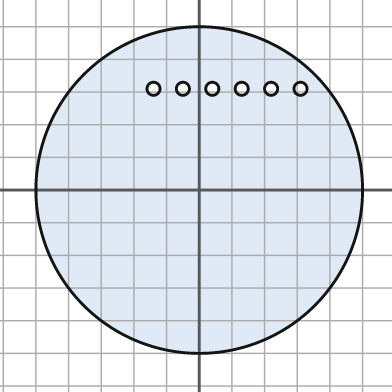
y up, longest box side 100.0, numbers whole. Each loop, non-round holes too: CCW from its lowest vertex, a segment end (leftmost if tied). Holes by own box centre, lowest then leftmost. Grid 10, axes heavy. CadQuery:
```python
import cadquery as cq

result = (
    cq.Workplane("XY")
    .moveTo(0.0, 0.0)
    .circle(50.0)
    .moveTo(-14.0, 31.0)
    .circle(2.0)
    .moveTo(-5.0, 31.0)
    .circle(2.0)
    .moveTo(4.0, 31.0)
    .circle(2.0)
    .moveTo(13.0, 31.0)
    .circle(2.0)
    .moveTo(22.0, 31.0)
    .circle(2.0)
    .moveTo(31.0, 31.0)
    .circle(2.0)
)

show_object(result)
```